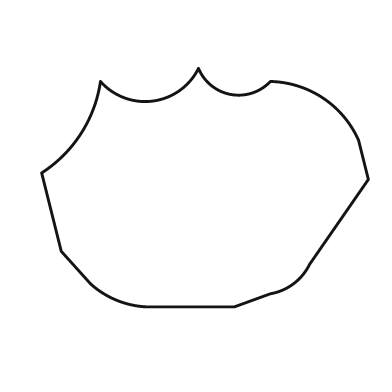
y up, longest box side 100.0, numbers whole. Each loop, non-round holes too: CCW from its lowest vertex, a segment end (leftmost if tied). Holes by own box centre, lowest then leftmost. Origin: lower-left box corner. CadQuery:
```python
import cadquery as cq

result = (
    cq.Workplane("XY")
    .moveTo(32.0, 0.0)
    .lineTo(59.0, 0.0)
    .lineTo(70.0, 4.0)
    .threePointArc((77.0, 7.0), (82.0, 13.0))
    .lineTo(100.0, 39.0)
    .lineTo(97.0, 51.0)
    .threePointArc((86.0, 64.0), (70.0, 69.0))
    .threePointArc((58.0, 65.0), (48.0, 73.0))
    .threePointArc((34.0, 63.0), (18.0, 69.0))
    .threePointArc((12.0, 53.0), (0.0, 41.0))
    .lineTo(6.0, 17.0)
    .lineTo(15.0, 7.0)
    .threePointArc((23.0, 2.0), (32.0, 0.0))
    .close()
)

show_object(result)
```